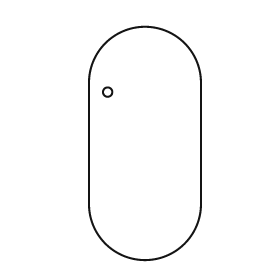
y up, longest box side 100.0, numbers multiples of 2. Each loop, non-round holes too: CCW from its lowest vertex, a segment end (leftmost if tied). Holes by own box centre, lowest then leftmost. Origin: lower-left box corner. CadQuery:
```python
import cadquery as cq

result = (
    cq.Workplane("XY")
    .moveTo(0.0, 24.0)
    .threePointArc((24.0, 0.0), (48.0, 24.0))
    .lineTo(48.0, 76.0)
    .threePointArc((24.0, 100.0), (0.0, 76.0))
    .close()
    .moveTo(8.0, 72.0)
    .circle(2.0)
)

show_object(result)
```